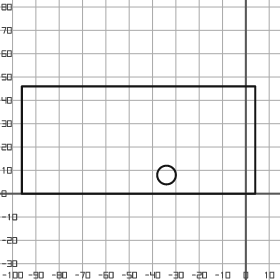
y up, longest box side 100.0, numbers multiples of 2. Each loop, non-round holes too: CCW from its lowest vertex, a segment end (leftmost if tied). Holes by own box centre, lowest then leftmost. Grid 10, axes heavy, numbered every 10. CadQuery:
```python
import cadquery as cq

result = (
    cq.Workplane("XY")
    .moveTo(-96.0, 0.0)
    .lineTo(4.0, 0.0)
    .lineTo(4.0, 46.0)
    .lineTo(-96.0, 46.0)
    .close()
    .moveTo(-34.0, 8.0)
    .circle(4.0)
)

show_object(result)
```